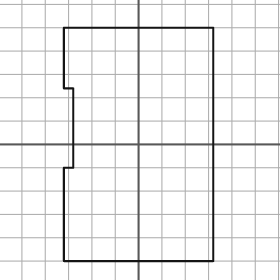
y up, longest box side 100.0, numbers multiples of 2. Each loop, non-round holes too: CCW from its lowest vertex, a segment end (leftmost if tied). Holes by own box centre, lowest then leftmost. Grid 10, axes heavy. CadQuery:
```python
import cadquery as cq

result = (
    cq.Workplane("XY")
    .moveTo(-32.0, -50.0)
    .lineTo(32.0, -50.0)
    .lineTo(32.0, 50.0)
    .lineTo(-32.0, 50.0)
    .lineTo(-32.0, 24.0)
    .lineTo(-28.0, 24.0)
    .lineTo(-28.0, -10.0)
    .lineTo(-32.0, -10.0)
    .close()
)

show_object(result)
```